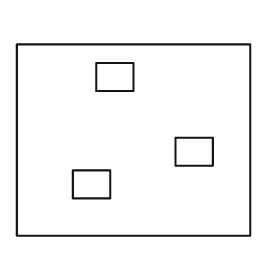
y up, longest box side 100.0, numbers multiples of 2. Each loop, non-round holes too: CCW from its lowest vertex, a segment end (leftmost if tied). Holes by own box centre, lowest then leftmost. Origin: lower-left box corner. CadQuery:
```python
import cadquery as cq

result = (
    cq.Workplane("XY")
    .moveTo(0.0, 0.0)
    .lineTo(100.0, 0.0)
    .lineTo(100.0, 82.0)
    .lineTo(0.0, 82.0)
    .close()
    .moveTo(24.0, 16.0)
    .lineTo(40.0, 16.0)
    .lineTo(40.0, 28.0)
    .lineTo(24.0, 28.0)
    .close()
    .moveTo(68.0, 30.0)
    .lineTo(84.0, 30.0)
    .lineTo(84.0, 42.0)
    .lineTo(68.0, 42.0)
    .close()
    .moveTo(34.0, 62.0)
    .lineTo(50.0, 62.0)
    .lineTo(50.0, 74.0)
    .lineTo(34.0, 74.0)
    .close()
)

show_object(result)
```